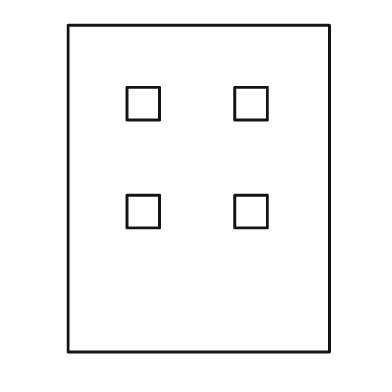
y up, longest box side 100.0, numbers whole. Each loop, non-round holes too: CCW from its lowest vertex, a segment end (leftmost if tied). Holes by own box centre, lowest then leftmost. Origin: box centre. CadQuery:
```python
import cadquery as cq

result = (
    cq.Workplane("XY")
    .moveTo(-40.0, -50.0)
    .lineTo(40.0, -50.0)
    .lineTo(40.0, 50.0)
    .lineTo(-40.0, 50.0)
    .close()
    .moveTo(-22.0, -12.0)
    .lineTo(-12.0, -12.0)
    .lineTo(-12.0, -2.0)
    .lineTo(-22.0, -2.0)
    .close()
    .moveTo(11.0, -12.0)
    .lineTo(21.0, -12.0)
    .lineTo(21.0, -2.0)
    .lineTo(11.0, -2.0)
    .close()
    .moveTo(-22.0, 21.0)
    .lineTo(-12.0, 21.0)
    .lineTo(-12.0, 31.0)
    .lineTo(-22.0, 31.0)
    .close()
    .moveTo(11.0, 21.0)
    .lineTo(21.0, 21.0)
    .lineTo(21.0, 31.0)
    .lineTo(11.0, 31.0)
    .close()
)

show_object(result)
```